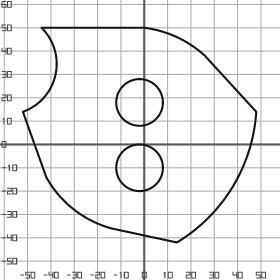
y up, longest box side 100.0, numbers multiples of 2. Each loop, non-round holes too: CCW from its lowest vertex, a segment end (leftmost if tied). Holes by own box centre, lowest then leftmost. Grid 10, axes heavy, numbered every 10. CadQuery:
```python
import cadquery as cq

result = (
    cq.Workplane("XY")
    .moveTo(14.0, -42.0)
    .threePointArc((38.0, -18.0), (48.0, 14.0))
    .lineTo(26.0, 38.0)
    .threePointArc((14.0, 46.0), (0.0, 50.0))
    .lineTo(-44.0, 50.0)
    .threePointArc((-38.0, 30.0), (-52.0, 14.0))
    .lineTo(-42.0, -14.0)
    .threePointArc((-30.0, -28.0), (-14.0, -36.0))
    .close()
    .moveTo(-2.0, -10.0)
    .circle(10.0)
    .moveTo(-2.0, 18.0)
    .circle(10.0)
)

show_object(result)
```